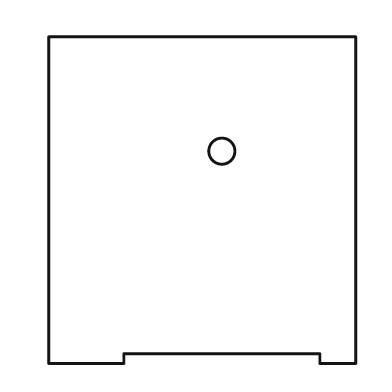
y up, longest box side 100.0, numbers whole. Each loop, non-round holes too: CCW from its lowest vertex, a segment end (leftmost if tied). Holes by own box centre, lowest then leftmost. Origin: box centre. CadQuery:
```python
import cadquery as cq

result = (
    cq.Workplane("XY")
    .moveTo(-47.0, -50.0)
    .lineTo(-24.0, -50.0)
    .lineTo(-24.0, -47.0)
    .lineTo(36.0, -47.0)
    .lineTo(36.0, -50.0)
    .lineTo(47.0, -50.0)
    .lineTo(47.0, 50.0)
    .lineTo(-47.0, 50.0)
    .close()
    .moveTo(6.0, 15.0)
    .circle(4.0)
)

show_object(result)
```